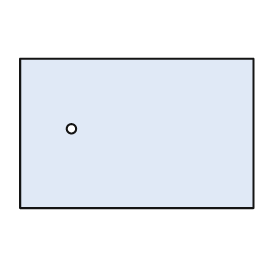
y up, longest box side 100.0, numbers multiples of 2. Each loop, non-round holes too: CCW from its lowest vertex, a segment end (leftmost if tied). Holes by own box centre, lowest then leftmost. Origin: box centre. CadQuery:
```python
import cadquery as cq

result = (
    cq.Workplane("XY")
    .moveTo(-50.0, -32.0)
    .lineTo(50.0, -32.0)
    .lineTo(50.0, 32.0)
    .lineTo(-50.0, 32.0)
    .close()
    .moveTo(-28.0, 2.0)
    .circle(2.0)
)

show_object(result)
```